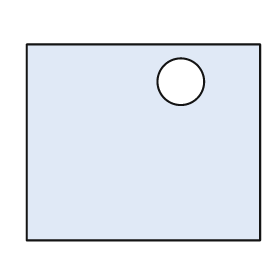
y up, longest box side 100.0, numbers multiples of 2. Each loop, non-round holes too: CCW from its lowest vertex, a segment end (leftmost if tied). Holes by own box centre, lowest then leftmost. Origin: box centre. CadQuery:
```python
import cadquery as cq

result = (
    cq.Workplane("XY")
    .moveTo(-50.0, -42.0)
    .lineTo(50.0, -42.0)
    .lineTo(50.0, 42.0)
    .lineTo(-50.0, 42.0)
    .close()
    .moveTo(16.0, 26.0)
    .circle(10.0)
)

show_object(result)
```